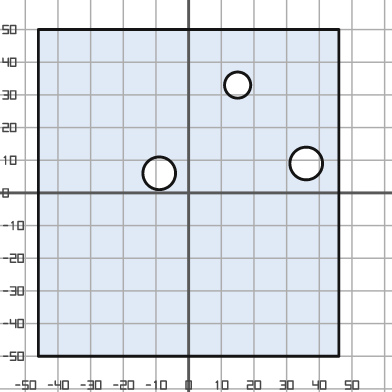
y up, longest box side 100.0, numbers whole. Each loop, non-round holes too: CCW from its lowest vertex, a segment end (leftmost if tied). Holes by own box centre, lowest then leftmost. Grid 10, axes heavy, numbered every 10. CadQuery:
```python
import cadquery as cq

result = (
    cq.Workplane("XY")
    .moveTo(-46.0, -50.0)
    .lineTo(46.0, -50.0)
    .lineTo(46.0, 50.0)
    .lineTo(-46.0, 50.0)
    .close()
    .moveTo(-9.0, 6.0)
    .circle(5.0)
    .moveTo(36.0, 9.0)
    .circle(5.0)
    .moveTo(15.0, 33.0)
    .circle(4.0)
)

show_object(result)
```